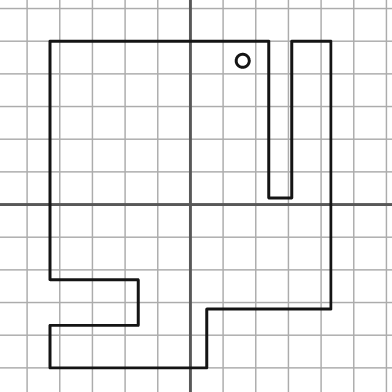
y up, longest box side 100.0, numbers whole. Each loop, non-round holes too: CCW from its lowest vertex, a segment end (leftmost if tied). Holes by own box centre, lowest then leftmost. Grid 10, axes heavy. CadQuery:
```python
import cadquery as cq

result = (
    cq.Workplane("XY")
    .moveTo(-43.0, -50.0)
    .lineTo(5.0, -50.0)
    .lineTo(5.0, -32.0)
    .lineTo(43.0, -32.0)
    .lineTo(43.0, 50.0)
    .lineTo(31.0, 50.0)
    .lineTo(31.0, 2.0)
    .lineTo(24.0, 2.0)
    .lineTo(24.0, 50.0)
    .lineTo(-43.0, 50.0)
    .lineTo(-43.0, -23.0)
    .lineTo(-16.0, -23.0)
    .lineTo(-16.0, -37.0)
    .lineTo(-43.0, -37.0)
    .close()
    .moveTo(16.0, 44.0)
    .circle(2.0)
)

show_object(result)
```